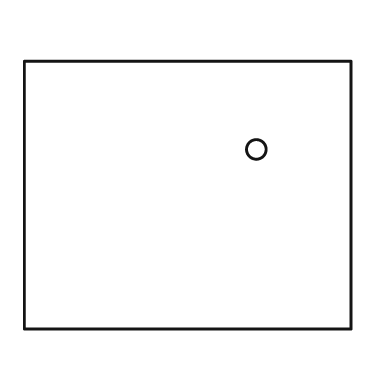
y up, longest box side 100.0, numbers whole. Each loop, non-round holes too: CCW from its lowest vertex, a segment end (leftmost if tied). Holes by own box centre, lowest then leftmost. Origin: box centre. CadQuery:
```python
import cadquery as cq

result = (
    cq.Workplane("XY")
    .moveTo(-50.0, -41.0)
    .lineTo(50.0, -41.0)
    .lineTo(50.0, 41.0)
    .lineTo(-50.0, 41.0)
    .close()
    .moveTo(21.0, 14.0)
    .circle(3.0)
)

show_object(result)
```